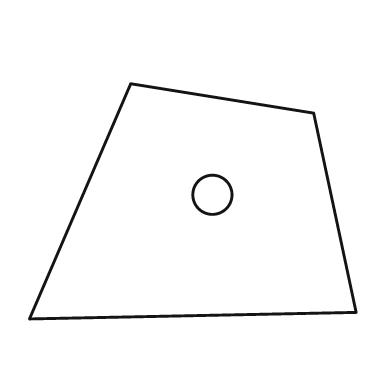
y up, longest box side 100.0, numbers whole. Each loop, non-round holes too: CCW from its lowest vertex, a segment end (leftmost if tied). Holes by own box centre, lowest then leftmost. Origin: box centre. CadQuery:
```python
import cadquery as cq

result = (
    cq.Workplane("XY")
    .moveTo(-50.0, -36.0)
    .lineTo(50.0, -34.0)
    .lineTo(37.0, 27.0)
    .lineTo(-19.0, 36.0)
    .close()
    .moveTo(6.0, 2.0)
    .circle(6.0)
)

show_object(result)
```